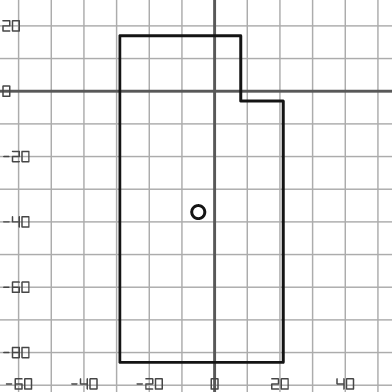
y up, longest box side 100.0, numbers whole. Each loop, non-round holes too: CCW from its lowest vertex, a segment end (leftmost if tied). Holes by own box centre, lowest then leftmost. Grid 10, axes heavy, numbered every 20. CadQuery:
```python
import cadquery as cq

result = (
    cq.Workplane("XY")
    .moveTo(-29.0, -83.0)
    .lineTo(21.0, -83.0)
    .lineTo(21.0, -3.0)
    .lineTo(8.0, -3.0)
    .lineTo(8.0, 17.0)
    .lineTo(-29.0, 17.0)
    .close()
    .moveTo(-5.0, -37.0)
    .circle(2.0)
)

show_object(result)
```